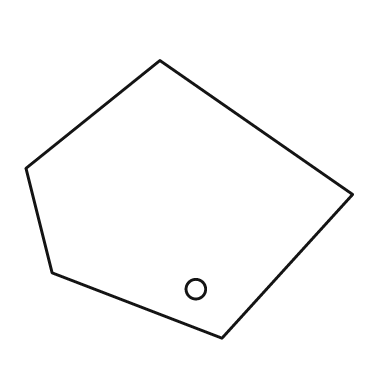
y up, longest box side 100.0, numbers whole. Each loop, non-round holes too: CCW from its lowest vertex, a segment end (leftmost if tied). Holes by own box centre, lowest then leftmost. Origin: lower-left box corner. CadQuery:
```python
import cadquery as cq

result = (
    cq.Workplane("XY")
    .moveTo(60.0, 0.0)
    .lineTo(100.0, 44.0)
    .lineTo(41.0, 85.0)
    .lineTo(0.0, 52.0)
    .lineTo(8.0, 20.0)
    .close()
    .moveTo(52.0, 15.0)
    .circle(3.0)
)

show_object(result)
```